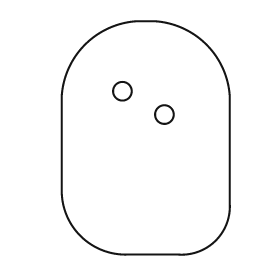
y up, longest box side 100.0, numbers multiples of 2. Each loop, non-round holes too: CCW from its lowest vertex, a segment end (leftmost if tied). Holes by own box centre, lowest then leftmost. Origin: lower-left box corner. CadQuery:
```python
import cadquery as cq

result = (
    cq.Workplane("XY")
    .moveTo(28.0, 0.0)
    .lineTo(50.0, 0.0)
    .threePointArc((66.0, 6.0), (72.0, 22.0))
    .lineTo(72.0, 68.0)
    .threePointArc((62.0, 90.0), (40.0, 100.0))
    .lineTo(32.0, 100.0)
    .threePointArc((10.0, 90.0), (0.0, 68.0))
    .lineTo(0.0, 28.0)
    .threePointArc((8.0, 8.0), (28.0, 0.0))
    .close()
    .moveTo(44.0, 60.0)
    .circle(4.0)
    .moveTo(26.0, 70.0)
    .circle(4.0)
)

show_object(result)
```